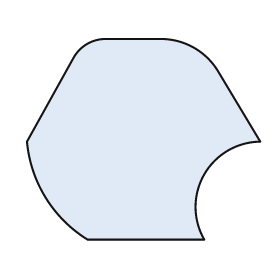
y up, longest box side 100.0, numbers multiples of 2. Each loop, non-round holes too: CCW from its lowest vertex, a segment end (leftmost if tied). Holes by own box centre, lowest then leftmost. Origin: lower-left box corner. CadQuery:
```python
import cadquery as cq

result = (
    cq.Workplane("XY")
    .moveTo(26.0, 0.0)
    .lineTo(76.0, 0.0)
    .threePointArc((76.0, 28.0), (100.0, 42.0))
    .lineTo(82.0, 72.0)
    .threePointArc((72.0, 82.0), (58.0, 86.0))
    .lineTo(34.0, 86.0)
    .threePointArc((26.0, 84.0), (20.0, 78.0))
    .lineTo(0.0, 42.0)
    .threePointArc((8.0, 18.0), (26.0, 0.0))
    .close()
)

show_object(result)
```